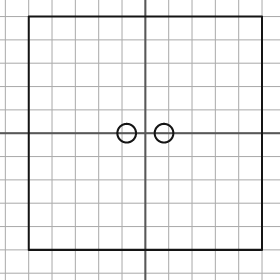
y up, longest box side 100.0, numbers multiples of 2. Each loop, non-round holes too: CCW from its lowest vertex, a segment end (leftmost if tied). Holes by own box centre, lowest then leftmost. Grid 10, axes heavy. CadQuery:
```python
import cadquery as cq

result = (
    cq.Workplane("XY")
    .moveTo(-50.0, -50.0)
    .lineTo(50.0, -50.0)
    .lineTo(50.0, 50.0)
    .lineTo(-50.0, 50.0)
    .close()
    .moveTo(-8.0, 0.0)
    .circle(4.0)
    .moveTo(8.0, 0.0)
    .circle(4.0)
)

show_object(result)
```